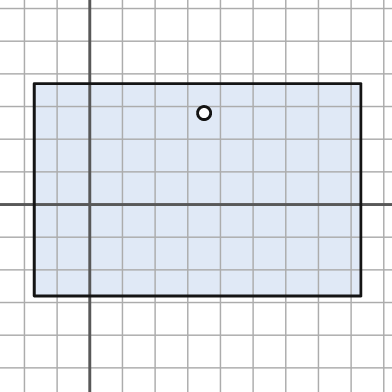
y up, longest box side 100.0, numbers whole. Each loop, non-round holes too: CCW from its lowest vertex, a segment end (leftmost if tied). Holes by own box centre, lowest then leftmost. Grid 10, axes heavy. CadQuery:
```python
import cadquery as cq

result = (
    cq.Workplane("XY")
    .moveTo(-17.0, -28.0)
    .lineTo(83.0, -28.0)
    .lineTo(83.0, 37.0)
    .lineTo(-17.0, 37.0)
    .close()
    .moveTo(35.0, 28.0)
    .circle(2.0)
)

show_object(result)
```